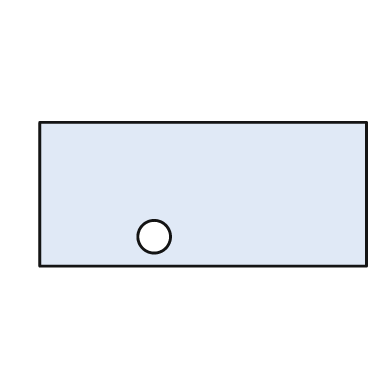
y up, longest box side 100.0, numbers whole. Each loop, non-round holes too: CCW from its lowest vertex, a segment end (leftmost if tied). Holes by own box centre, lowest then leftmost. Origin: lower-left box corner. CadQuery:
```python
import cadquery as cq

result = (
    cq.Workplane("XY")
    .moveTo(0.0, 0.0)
    .lineTo(100.0, 0.0)
    .lineTo(100.0, 44.0)
    .lineTo(0.0, 44.0)
    .close()
    .moveTo(35.0, 9.0)
    .circle(5.0)
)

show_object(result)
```